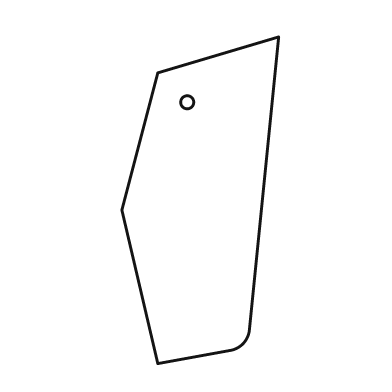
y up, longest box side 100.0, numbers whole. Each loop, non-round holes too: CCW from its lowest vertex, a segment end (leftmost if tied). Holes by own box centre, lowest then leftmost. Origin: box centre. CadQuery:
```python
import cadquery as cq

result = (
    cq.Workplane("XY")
    .moveTo(-13.0, -50.0)
    .lineTo(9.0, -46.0)
    .threePointArc((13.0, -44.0), (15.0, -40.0))
    .lineTo(24.0, 50.0)
    .lineTo(-13.0, 39.0)
    .lineTo(-24.0, -3.0)
    .close()
    .moveTo(-4.0, 30.0)
    .circle(2.0)
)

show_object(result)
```